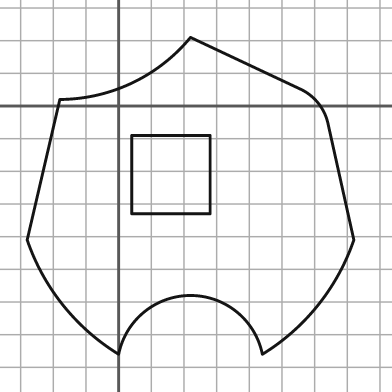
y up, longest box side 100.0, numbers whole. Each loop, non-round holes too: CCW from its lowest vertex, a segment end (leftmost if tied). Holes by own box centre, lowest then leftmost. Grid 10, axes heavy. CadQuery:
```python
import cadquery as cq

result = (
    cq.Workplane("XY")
    .moveTo(0.0, -76.0)
    .threePointArc((22.0, -58.0), (44.0, -76.0))
    .threePointArc((61.0, -61.0), (72.0, -41.0))
    .lineTo(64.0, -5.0)
    .threePointArc((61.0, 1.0), (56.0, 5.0))
    .lineTo(22.0, 21.0)
    .threePointArc((4.0, 7.0), (-18.0, 2.0))
    .lineTo(-28.0, -41.0)
    .threePointArc((-17.0, -61.0), (0.0, -76.0))
    .close()
    .moveTo(4.0, -33.0)
    .lineTo(28.0, -33.0)
    .lineTo(28.0, -9.0)
    .lineTo(4.0, -9.0)
    .close()
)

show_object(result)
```